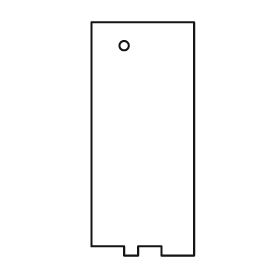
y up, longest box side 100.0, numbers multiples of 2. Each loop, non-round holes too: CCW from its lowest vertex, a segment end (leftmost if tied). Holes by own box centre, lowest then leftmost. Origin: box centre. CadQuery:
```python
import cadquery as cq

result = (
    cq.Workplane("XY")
    .moveTo(-8.0, -50.0)
    .lineTo(-2.0, -50.0)
    .lineTo(-2.0, -46.0)
    .lineTo(8.0, -46.0)
    .lineTo(8.0, -50.0)
    .lineTo(22.0, -50.0)
    .lineTo(22.0, 50.0)
    .lineTo(-22.0, 50.0)
    .lineTo(-22.0, -46.0)
    .lineTo(-8.0, -46.0)
    .close()
    .moveTo(-8.0, 40.0)
    .circle(2.0)
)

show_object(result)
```